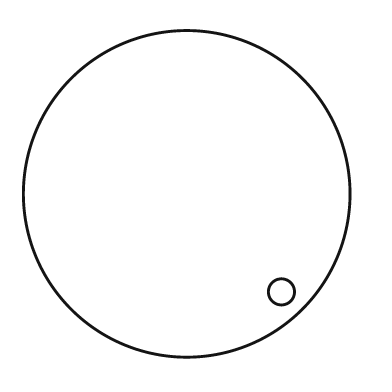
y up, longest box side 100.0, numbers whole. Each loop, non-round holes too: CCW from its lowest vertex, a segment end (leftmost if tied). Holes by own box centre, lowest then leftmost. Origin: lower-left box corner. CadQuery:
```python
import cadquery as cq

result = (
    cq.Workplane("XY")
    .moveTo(50.0, 50.0)
    .circle(50.0)
    .moveTo(79.0, 20.0)
    .circle(4.0)
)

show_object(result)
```